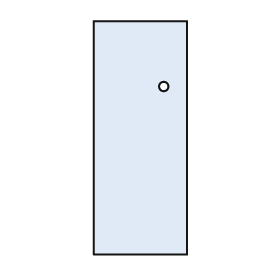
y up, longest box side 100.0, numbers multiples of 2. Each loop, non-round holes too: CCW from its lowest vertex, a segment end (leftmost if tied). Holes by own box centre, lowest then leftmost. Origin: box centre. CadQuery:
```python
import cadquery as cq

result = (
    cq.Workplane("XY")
    .moveTo(-20.0, -50.0)
    .lineTo(20.0, -50.0)
    .lineTo(20.0, 50.0)
    .lineTo(-20.0, 50.0)
    .close()
    .moveTo(10.0, 22.0)
    .circle(2.0)
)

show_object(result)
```